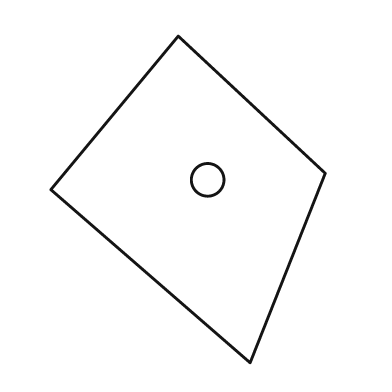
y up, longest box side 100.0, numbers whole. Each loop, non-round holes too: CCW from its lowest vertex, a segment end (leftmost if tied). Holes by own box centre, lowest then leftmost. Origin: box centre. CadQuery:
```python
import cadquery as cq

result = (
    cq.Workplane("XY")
    .moveTo(19.0, -50.0)
    .lineTo(42.0, 8.0)
    .lineTo(-3.0, 50.0)
    .lineTo(-42.0, 3.0)
    .close()
    .moveTo(6.0, 6.0)
    .circle(5.0)
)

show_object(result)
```